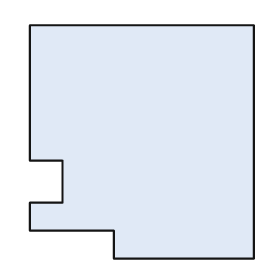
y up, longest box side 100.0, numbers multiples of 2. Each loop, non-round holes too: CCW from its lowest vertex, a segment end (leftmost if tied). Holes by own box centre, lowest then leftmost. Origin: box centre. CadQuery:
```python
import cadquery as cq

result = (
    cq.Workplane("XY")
    .moveTo(-12.0, -50.0)
    .lineTo(48.0, -50.0)
    .lineTo(48.0, 50.0)
    .lineTo(-48.0, 50.0)
    .lineTo(-48.0, -8.0)
    .lineTo(-34.0, -8.0)
    .lineTo(-34.0, -26.0)
    .lineTo(-48.0, -26.0)
    .lineTo(-48.0, -38.0)
    .lineTo(-12.0, -38.0)
    .close()
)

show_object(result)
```